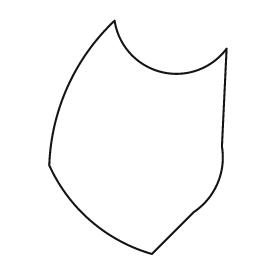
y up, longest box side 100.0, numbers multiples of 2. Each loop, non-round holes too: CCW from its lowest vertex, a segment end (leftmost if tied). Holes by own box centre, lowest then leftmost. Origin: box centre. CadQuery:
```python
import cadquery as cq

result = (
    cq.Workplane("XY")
    .moveTo(6.0, -50.0)
    .lineTo(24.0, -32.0)
    .threePointArc((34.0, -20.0), (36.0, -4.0))
    .lineTo(38.0, 38.0)
    .threePointArc((10.0, 28.0), (-10.0, 50.0))
    .threePointArc((-30.0, 22.0), (-38.0, -12.0))
    .threePointArc((-20.0, -36.0), (6.0, -50.0))
    .close()
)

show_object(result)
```